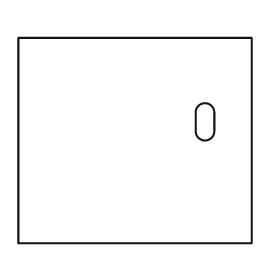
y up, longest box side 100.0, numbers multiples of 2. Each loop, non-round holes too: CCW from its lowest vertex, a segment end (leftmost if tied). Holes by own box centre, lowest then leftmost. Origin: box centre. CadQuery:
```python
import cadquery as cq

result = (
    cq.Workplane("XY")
    .moveTo(-50.0, -44.0)
    .lineTo(50.0, -44.0)
    .lineTo(50.0, 44.0)
    .lineTo(-50.0, 44.0)
    .close()
    .moveTo(26.0, 4.0)
    .threePointArc((30.0, 0.0), (34.0, 4.0))
    .lineTo(34.0, 12.0)
    .threePointArc((30.0, 16.0), (26.0, 12.0))
    .close()
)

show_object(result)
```